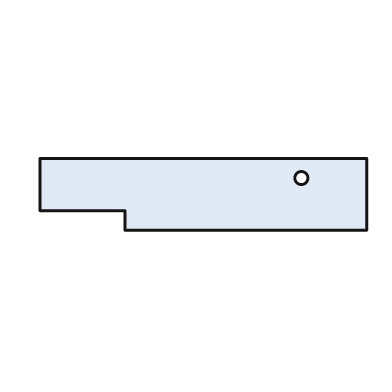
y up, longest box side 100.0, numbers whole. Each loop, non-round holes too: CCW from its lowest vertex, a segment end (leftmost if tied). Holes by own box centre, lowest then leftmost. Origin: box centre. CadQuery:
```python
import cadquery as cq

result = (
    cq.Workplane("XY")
    .moveTo(-24.0, -11.0)
    .lineTo(50.0, -11.0)
    .lineTo(50.0, 11.0)
    .lineTo(-50.0, 11.0)
    .lineTo(-50.0, -5.0)
    .lineTo(-24.0, -5.0)
    .close()
    .moveTo(30.0, 5.0)
    .circle(2.0)
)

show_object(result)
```